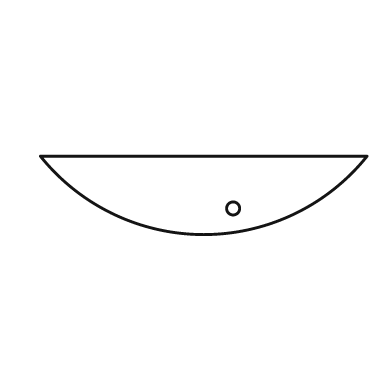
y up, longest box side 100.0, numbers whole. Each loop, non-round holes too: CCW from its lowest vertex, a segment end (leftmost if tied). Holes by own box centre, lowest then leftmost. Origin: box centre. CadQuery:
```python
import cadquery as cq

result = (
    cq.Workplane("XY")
    .moveTo(-50.0, 12.0)
    .threePointArc((0.0, -12.0), (50.0, 12.0))
    .close()
    .moveTo(9.0, -4.0)
    .circle(2.0)
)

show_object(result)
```